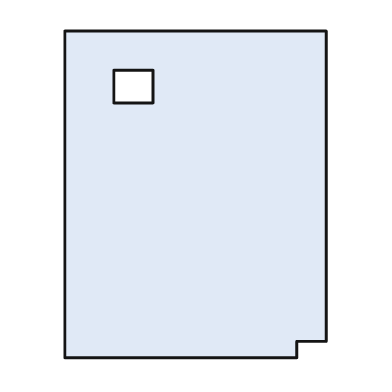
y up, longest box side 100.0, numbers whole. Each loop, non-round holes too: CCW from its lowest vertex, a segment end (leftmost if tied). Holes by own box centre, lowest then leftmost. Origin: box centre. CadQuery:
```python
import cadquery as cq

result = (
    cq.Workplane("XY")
    .moveTo(-40.0, -50.0)
    .lineTo(31.0, -50.0)
    .lineTo(31.0, -45.0)
    .lineTo(40.0, -45.0)
    .lineTo(40.0, 50.0)
    .lineTo(-40.0, 50.0)
    .close()
    .moveTo(-25.0, 28.0)
    .lineTo(-13.0, 28.0)
    .lineTo(-13.0, 38.0)
    .lineTo(-25.0, 38.0)
    .close()
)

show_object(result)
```